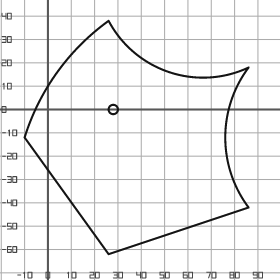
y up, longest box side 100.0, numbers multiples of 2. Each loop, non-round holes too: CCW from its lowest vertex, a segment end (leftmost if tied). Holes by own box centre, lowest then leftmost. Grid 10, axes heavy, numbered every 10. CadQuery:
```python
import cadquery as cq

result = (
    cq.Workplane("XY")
    .moveTo(26.0, -62.0)
    .lineTo(86.0, -42.0)
    .threePointArc((76.0, -12.0), (86.0, 18.0))
    .threePointArc((52.0, 16.0), (26.0, 38.0))
    .threePointArc((4.0, 16.0), (-10.0, -12.0))
    .close()
    .moveTo(28.0, 0.0)
    .circle(2.0)
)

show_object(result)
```